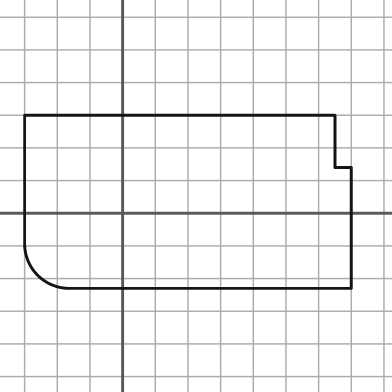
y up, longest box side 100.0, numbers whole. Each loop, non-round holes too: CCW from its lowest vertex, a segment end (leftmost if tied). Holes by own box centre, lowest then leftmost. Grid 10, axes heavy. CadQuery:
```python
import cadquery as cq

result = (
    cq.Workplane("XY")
    .moveTo(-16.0, -23.0)
    .lineTo(70.0, -23.0)
    .lineTo(70.0, 14.0)
    .lineTo(65.0, 14.0)
    .lineTo(65.0, 30.0)
    .lineTo(-30.0, 30.0)
    .lineTo(-30.0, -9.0)
    .threePointArc((-26.0, -19.0), (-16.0, -23.0))
    .close()
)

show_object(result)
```